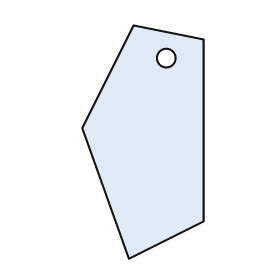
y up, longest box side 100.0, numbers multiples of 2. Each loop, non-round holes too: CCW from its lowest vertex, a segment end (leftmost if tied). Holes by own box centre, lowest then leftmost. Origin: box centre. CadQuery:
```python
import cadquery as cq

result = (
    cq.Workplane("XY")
    .moveTo(-6.0, -50.0)
    .lineTo(26.0, -34.0)
    .lineTo(26.0, 44.0)
    .lineTo(-4.0, 50.0)
    .lineTo(-26.0, 6.0)
    .close()
    .moveTo(10.0, 36.0)
    .circle(4.0)
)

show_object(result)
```